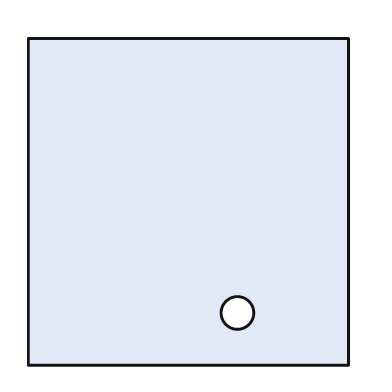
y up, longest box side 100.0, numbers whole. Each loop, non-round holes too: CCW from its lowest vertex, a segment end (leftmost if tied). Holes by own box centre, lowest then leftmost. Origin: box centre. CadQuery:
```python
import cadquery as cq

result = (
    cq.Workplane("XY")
    .moveTo(-49.0, -50.0)
    .lineTo(49.0, -50.0)
    .lineTo(49.0, 50.0)
    .lineTo(-49.0, 50.0)
    .close()
    .moveTo(15.0, -34.0)
    .circle(5.0)
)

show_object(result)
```